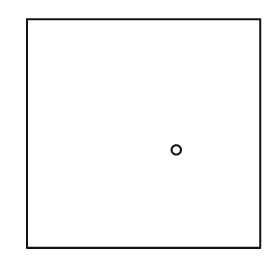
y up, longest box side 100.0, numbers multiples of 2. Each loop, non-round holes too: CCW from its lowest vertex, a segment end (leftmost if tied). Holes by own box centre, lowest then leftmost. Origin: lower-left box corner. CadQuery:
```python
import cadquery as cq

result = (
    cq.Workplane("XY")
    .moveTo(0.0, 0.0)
    .lineTo(100.0, 0.0)
    .lineTo(100.0, 98.0)
    .lineTo(0.0, 98.0)
    .close()
    .moveTo(64.0, 42.0)
    .circle(2.0)
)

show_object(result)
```